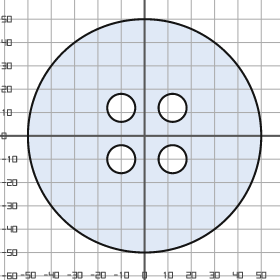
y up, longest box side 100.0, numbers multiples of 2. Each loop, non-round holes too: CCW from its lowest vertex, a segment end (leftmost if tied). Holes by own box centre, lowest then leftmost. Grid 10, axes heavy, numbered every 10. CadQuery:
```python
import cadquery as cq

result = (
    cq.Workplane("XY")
    .moveTo(0.0, 0.0)
    .circle(50.0)
    .moveTo(-10.0, -10.0)
    .circle(6.0)
    .moveTo(12.0, -10.0)
    .circle(6.0)
    .moveTo(-10.0, 12.0)
    .circle(6.0)
    .moveTo(12.0, 12.0)
    .circle(6.0)
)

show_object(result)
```